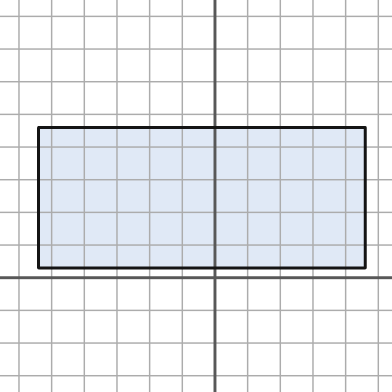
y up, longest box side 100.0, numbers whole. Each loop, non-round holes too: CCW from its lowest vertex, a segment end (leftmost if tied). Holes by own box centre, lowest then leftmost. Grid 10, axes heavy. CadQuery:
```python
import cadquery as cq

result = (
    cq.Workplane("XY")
    .moveTo(-54.0, 3.0)
    .lineTo(46.0, 3.0)
    .lineTo(46.0, 46.0)
    .lineTo(-54.0, 46.0)
    .close()
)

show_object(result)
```